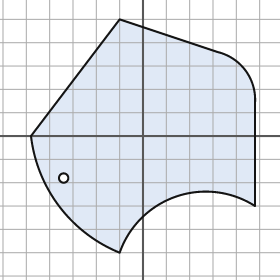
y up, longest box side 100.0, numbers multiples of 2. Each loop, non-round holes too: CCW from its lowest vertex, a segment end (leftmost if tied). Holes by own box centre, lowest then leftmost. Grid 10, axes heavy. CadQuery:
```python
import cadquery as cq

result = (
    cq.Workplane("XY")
    .moveTo(-10.0, -50.0)
    .threePointArc((14.0, -26.0), (48.0, -30.0))
    .lineTo(48.0, 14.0)
    .threePointArc((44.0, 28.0), (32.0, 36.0))
    .lineTo(-10.0, 50.0)
    .lineTo(-48.0, 0.0)
    .threePointArc((-36.0, -30.0), (-10.0, -50.0))
    .close()
    .moveTo(-34.0, -18.0)
    .circle(2.0)
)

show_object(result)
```